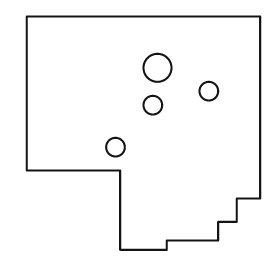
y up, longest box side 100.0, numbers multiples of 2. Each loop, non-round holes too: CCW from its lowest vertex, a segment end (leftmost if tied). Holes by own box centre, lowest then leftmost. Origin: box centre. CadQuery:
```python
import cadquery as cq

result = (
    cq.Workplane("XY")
    .moveTo(-10.0, -50.0)
    .lineTo(10.0, -50.0)
    .lineTo(10.0, -46.0)
    .lineTo(32.0, -46.0)
    .lineTo(32.0, -38.0)
    .lineTo(40.0, -38.0)
    .lineTo(40.0, -28.0)
    .lineTo(50.0, -28.0)
    .lineTo(50.0, 50.0)
    .lineTo(-50.0, 50.0)
    .lineTo(-50.0, -16.0)
    .lineTo(-10.0, -16.0)
    .close()
    .moveTo(-12.0, -6.0)
    .circle(4.0)
    .moveTo(4.0, 12.0)
    .circle(4.0)
    .moveTo(28.0, 18.0)
    .circle(4.0)
    .moveTo(6.0, 28.0)
    .circle(6.0)
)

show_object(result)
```